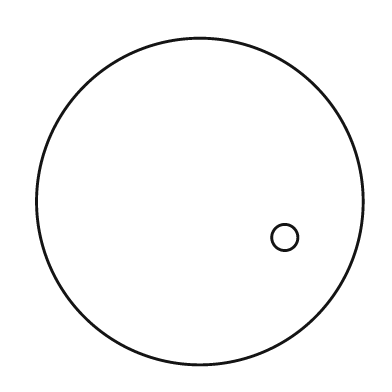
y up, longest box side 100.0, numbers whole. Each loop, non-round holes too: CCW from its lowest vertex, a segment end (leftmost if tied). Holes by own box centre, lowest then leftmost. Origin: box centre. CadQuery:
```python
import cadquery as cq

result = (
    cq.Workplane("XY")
    .moveTo(0.0, 0.0)
    .circle(50.0)
    .moveTo(26.0, -11.0)
    .circle(4.0)
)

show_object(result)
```